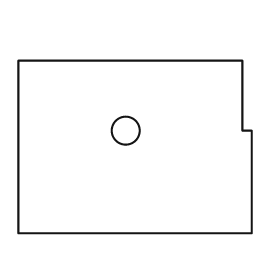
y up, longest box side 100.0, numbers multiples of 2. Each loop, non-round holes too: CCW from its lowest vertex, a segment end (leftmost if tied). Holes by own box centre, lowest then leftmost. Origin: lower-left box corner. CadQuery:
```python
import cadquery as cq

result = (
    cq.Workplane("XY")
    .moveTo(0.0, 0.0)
    .lineTo(100.0, 0.0)
    .lineTo(100.0, 44.0)
    .lineTo(96.0, 44.0)
    .lineTo(96.0, 74.0)
    .lineTo(0.0, 74.0)
    .close()
    .moveTo(46.0, 44.0)
    .circle(6.0)
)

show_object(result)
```